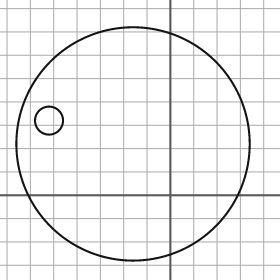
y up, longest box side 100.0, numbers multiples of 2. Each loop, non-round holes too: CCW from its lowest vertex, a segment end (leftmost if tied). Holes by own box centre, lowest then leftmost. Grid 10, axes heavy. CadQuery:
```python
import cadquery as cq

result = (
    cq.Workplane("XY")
    .moveTo(-16.0, 22.0)
    .circle(50.0)
    .moveTo(-52.0, 32.0)
    .circle(6.0)
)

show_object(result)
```